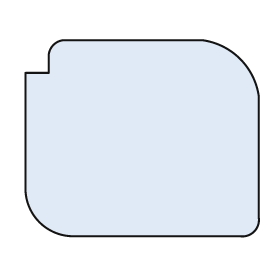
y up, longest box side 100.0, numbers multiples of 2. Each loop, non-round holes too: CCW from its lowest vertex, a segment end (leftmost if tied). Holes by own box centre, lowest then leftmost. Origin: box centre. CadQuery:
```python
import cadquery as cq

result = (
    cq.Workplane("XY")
    .moveTo(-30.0, -42.0)
    .lineTo(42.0, -42.0)
    .threePointArc((48.0, -40.0), (50.0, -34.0))
    .lineTo(50.0, 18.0)
    .threePointArc((42.0, 34.0), (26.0, 42.0))
    .lineTo(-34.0, 42.0)
    .threePointArc((-38.0, 40.0), (-40.0, 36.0))
    .lineTo(-40.0, 28.0)
    .lineTo(-50.0, 28.0)
    .lineTo(-50.0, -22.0)
    .threePointArc((-44.0, -36.0), (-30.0, -42.0))
    .close()
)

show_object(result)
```